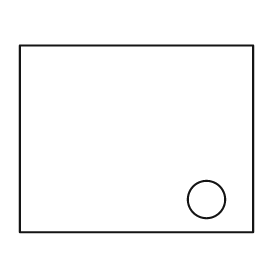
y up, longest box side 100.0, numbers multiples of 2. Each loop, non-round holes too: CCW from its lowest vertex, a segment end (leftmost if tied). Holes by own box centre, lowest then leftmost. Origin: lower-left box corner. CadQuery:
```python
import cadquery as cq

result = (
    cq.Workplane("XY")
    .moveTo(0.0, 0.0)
    .lineTo(100.0, 0.0)
    .lineTo(100.0, 80.0)
    .lineTo(0.0, 80.0)
    .close()
    .moveTo(80.0, 14.0)
    .circle(8.0)
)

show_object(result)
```